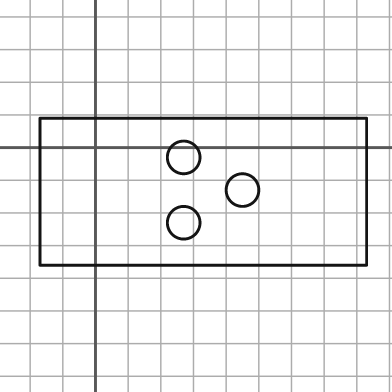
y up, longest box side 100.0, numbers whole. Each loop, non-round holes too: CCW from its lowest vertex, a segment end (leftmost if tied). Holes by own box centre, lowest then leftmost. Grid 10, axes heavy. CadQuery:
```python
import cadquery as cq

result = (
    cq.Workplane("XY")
    .moveTo(-17.0, -36.0)
    .lineTo(83.0, -36.0)
    .lineTo(83.0, 9.0)
    .lineTo(-17.0, 9.0)
    .close()
    .moveTo(27.0, -23.0)
    .circle(5.0)
    .moveTo(45.0, -13.0)
    .circle(5.0)
    .moveTo(27.0, -3.0)
    .circle(5.0)
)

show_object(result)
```